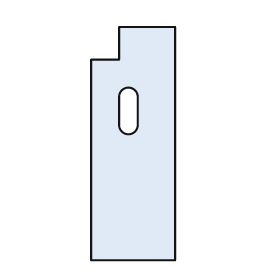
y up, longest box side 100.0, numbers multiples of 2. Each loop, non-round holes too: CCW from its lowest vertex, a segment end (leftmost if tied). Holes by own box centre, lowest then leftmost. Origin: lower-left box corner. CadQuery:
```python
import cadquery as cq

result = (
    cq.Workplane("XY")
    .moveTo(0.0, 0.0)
    .lineTo(36.0, 0.0)
    .lineTo(36.0, 100.0)
    .lineTo(12.0, 100.0)
    .lineTo(12.0, 86.0)
    .lineTo(0.0, 86.0)
    .close()
    .moveTo(12.0, 58.0)
    .threePointArc((16.0, 54.0), (20.0, 58.0))
    .lineTo(20.0, 70.0)
    .threePointArc((16.0, 74.0), (12.0, 70.0))
    .close()
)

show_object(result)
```